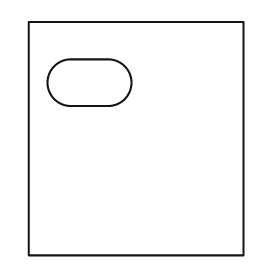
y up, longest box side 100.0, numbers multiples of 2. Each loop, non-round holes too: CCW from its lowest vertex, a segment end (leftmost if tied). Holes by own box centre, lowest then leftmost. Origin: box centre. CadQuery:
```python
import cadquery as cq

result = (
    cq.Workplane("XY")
    .moveTo(-46.0, -50.0)
    .lineTo(46.0, -50.0)
    .lineTo(46.0, 50.0)
    .lineTo(-46.0, 50.0)
    .close()
    .moveTo(-28.0, 14.0)
    .lineTo(-12.0, 14.0)
    .threePointArc((-2.0, 24.0), (-12.0, 34.0))
    .lineTo(-28.0, 34.0)
    .threePointArc((-38.0, 24.0), (-28.0, 14.0))
    .close()
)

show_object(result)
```